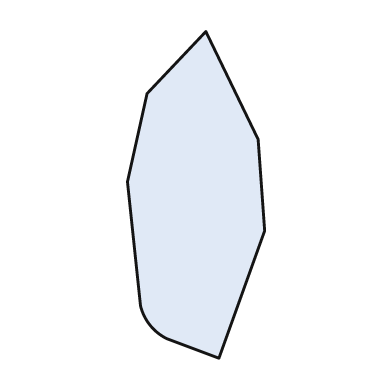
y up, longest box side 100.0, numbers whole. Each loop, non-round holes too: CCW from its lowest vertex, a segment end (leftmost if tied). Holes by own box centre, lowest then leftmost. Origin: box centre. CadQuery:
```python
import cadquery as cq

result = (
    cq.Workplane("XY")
    .moveTo(7.0, -50.0)
    .lineTo(21.0, -11.0)
    .lineTo(19.0, 17.0)
    .lineTo(3.0, 50.0)
    .lineTo(-15.0, 31.0)
    .lineTo(-21.0, 4.0)
    .lineTo(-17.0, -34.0)
    .threePointArc((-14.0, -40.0), (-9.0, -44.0))
    .close()
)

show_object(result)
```